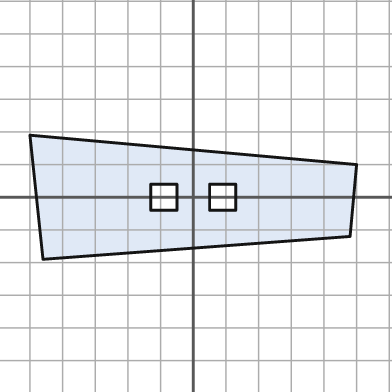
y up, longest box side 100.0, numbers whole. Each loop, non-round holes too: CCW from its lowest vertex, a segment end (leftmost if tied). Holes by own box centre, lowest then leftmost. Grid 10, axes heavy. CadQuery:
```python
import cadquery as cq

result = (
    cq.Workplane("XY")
    .moveTo(-46.0, -19.0)
    .lineTo(48.0, -12.0)
    .lineTo(50.0, 10.0)
    .lineTo(-50.0, 19.0)
    .close()
    .moveTo(-13.0, -4.0)
    .lineTo(-5.0, -4.0)
    .lineTo(-5.0, 4.0)
    .lineTo(-13.0, 4.0)
    .close()
    .moveTo(5.0, -4.0)
    .lineTo(13.0, -4.0)
    .lineTo(13.0, 4.0)
    .lineTo(5.0, 4.0)
    .close()
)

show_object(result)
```